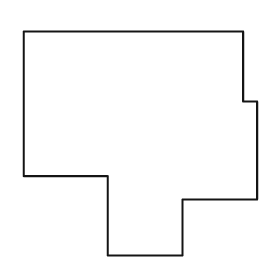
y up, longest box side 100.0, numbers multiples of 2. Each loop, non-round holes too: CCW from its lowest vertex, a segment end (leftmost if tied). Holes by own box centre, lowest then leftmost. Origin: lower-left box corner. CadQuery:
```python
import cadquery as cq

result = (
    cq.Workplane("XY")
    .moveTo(36.0, 0.0)
    .lineTo(68.0, 0.0)
    .lineTo(68.0, 24.0)
    .lineTo(100.0, 24.0)
    .lineTo(100.0, 66.0)
    .lineTo(94.0, 66.0)
    .lineTo(94.0, 96.0)
    .lineTo(0.0, 96.0)
    .lineTo(0.0, 34.0)
    .lineTo(36.0, 34.0)
    .close()
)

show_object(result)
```